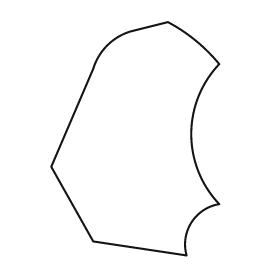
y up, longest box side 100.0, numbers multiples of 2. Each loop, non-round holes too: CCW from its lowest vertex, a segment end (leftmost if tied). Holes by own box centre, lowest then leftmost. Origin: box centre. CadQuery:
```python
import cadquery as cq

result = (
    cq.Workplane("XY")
    .moveTo(22.0, -50.0)
    .threePointArc((24.0, -36.0), (36.0, -28.0))
    .threePointArc((24.0, 2.0), (36.0, 32.0))
    .threePointArc((26.0, 42.0), (14.0, 50.0))
    .lineTo(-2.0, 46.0)
    .threePointArc((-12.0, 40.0), (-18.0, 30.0))
    .lineTo(-36.0, -12.0)
    .lineTo(-18.0, -44.0)
    .close()
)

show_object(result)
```